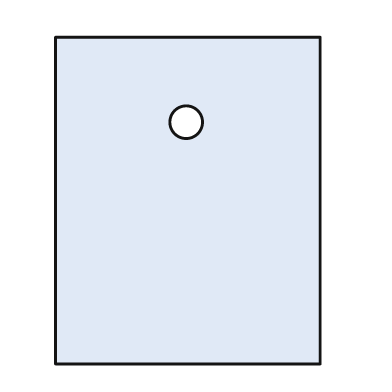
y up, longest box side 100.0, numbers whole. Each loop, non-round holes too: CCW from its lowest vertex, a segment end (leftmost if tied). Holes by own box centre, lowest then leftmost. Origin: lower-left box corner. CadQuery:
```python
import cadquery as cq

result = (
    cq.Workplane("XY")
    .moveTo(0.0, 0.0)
    .lineTo(81.0, 0.0)
    .lineTo(81.0, 100.0)
    .lineTo(0.0, 100.0)
    .close()
    .moveTo(40.0, 74.0)
    .circle(5.0)
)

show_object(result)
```